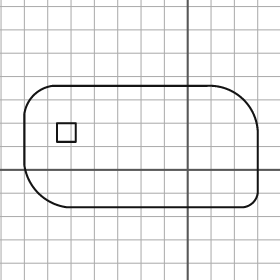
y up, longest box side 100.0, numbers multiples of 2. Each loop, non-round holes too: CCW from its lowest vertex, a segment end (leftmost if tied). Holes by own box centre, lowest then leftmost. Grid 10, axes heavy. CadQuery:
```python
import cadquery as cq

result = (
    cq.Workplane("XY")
    .moveTo(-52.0, -16.0)
    .lineTo(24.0, -16.0)
    .threePointArc((28.0, -14.0), (30.0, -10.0))
    .lineTo(30.0, 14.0)
    .threePointArc((24.0, 30.0), (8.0, 36.0))
    .lineTo(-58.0, 36.0)
    .threePointArc((-66.0, 32.0), (-70.0, 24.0))
    .lineTo(-70.0, 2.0)
    .threePointArc((-64.0, -10.0), (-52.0, -16.0))
    .close()
    .moveTo(-56.0, 12.0)
    .lineTo(-48.0, 12.0)
    .lineTo(-48.0, 20.0)
    .lineTo(-56.0, 20.0)
    .close()
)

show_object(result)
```